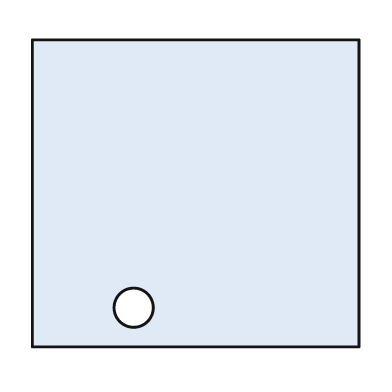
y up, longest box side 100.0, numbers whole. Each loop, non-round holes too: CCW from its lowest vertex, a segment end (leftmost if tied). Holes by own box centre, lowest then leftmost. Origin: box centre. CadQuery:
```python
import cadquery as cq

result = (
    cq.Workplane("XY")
    .moveTo(-50.0, -47.0)
    .lineTo(50.0, -47.0)
    .lineTo(50.0, 47.0)
    .lineTo(-50.0, 47.0)
    .close()
    .moveTo(-19.0, -35.0)
    .circle(6.0)
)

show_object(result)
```